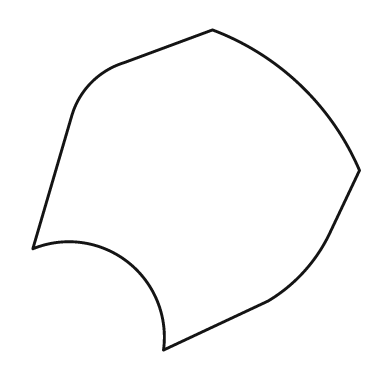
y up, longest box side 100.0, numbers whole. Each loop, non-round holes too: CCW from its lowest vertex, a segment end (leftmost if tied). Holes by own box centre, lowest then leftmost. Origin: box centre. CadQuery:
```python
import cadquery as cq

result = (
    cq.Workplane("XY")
    .moveTo(-10.0, -49.0)
    .lineTo(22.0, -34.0)
    .threePointArc((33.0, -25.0), (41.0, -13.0))
    .lineTo(50.0, 6.0)
    .threePointArc((32.0, 32.0), (5.0, 49.0))
    .lineTo(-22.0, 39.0)
    .threePointArc((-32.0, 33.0), (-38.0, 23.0))
    .lineTo(-50.0, -18.0)
    .threePointArc((-21.0, -22.0), (-10.0, -49.0))
    .close()
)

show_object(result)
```